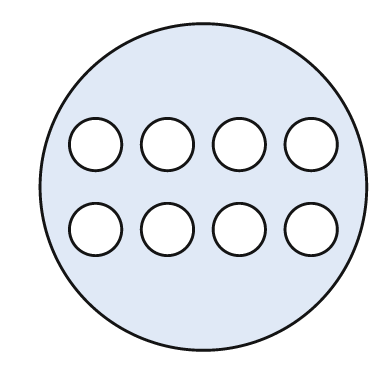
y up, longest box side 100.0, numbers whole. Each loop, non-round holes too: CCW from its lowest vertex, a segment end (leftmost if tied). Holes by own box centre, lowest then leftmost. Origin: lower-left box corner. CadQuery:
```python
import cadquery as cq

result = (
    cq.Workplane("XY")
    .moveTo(50.0, 50.0)
    .circle(50.0)
    .moveTo(17.0, 37.0)
    .circle(8.0)
    .moveTo(39.0, 37.0)
    .circle(8.0)
    .moveTo(61.0, 37.0)
    .circle(8.0)
    .moveTo(83.0, 37.0)
    .circle(8.0)
    .moveTo(17.0, 63.0)
    .circle(8.0)
    .moveTo(39.0, 63.0)
    .circle(8.0)
    .moveTo(61.0, 63.0)
    .circle(8.0)
    .moveTo(83.0, 63.0)
    .circle(8.0)
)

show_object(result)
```